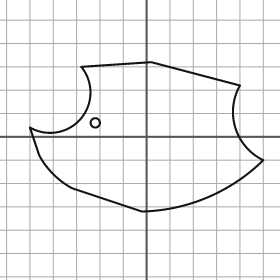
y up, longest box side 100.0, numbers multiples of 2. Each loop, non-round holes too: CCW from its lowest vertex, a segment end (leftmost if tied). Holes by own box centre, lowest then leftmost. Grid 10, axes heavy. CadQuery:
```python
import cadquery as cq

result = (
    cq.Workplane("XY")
    .moveTo(-2.0, -32.0)
    .threePointArc((26.0, -26.0), (50.0, -10.0))
    .threePointArc((38.0, 4.0), (40.0, 22.0))
    .lineTo(2.0, 32.0)
    .lineTo(-28.0, 30.0)
    .threePointArc((-28.0, 8.0), (-50.0, 4.0))
    .lineTo(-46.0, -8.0)
    .threePointArc((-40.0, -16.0), (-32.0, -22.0))
    .close()
    .moveTo(-22.0, 6.0)
    .circle(2.0)
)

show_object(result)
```